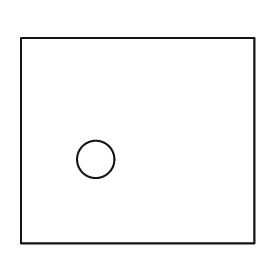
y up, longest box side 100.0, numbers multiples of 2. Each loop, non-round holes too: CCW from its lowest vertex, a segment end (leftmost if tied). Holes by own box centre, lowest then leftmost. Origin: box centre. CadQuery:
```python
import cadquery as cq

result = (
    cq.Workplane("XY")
    .moveTo(-50.0, -44.0)
    .lineTo(50.0, -44.0)
    .lineTo(50.0, 44.0)
    .lineTo(-50.0, 44.0)
    .close()
    .moveTo(-18.0, -8.0)
    .circle(8.0)
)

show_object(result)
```